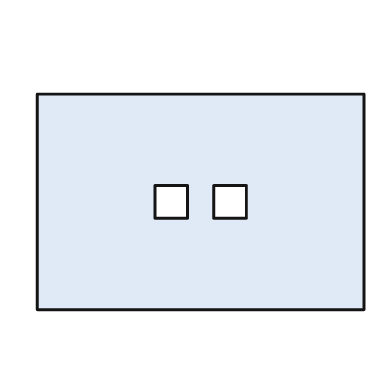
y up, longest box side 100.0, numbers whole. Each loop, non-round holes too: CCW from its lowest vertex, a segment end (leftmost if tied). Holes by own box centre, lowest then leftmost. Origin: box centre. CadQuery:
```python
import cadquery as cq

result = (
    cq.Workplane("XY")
    .moveTo(-50.0, -33.0)
    .lineTo(50.0, -33.0)
    .lineTo(50.0, 33.0)
    .lineTo(-50.0, 33.0)
    .close()
    .moveTo(-14.0, -5.0)
    .lineTo(-4.0, -5.0)
    .lineTo(-4.0, 5.0)
    .lineTo(-14.0, 5.0)
    .close()
    .moveTo(4.0, -5.0)
    .lineTo(14.0, -5.0)
    .lineTo(14.0, 5.0)
    .lineTo(4.0, 5.0)
    .close()
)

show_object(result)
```